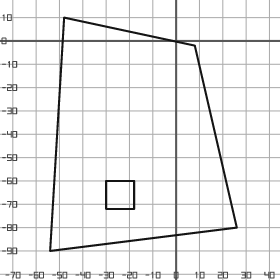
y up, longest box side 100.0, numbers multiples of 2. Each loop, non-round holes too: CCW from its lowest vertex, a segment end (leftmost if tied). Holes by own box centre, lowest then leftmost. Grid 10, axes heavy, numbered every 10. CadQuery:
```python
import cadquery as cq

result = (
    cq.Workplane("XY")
    .moveTo(-54.0, -90.0)
    .lineTo(26.0, -80.0)
    .lineTo(8.0, -2.0)
    .lineTo(-48.0, 10.0)
    .close()
    .moveTo(-30.0, -72.0)
    .lineTo(-18.0, -72.0)
    .lineTo(-18.0, -60.0)
    .lineTo(-30.0, -60.0)
    .close()
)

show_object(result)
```